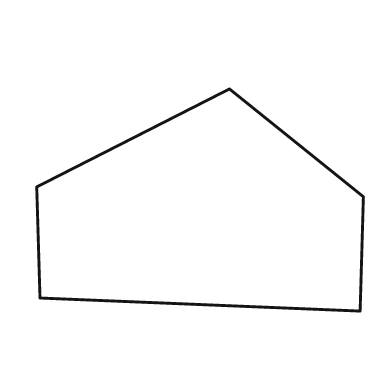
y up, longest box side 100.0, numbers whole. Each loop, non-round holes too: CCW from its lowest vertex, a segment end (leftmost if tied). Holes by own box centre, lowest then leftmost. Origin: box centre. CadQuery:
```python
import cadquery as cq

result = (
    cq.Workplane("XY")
    .moveTo(49.0, -34.0)
    .lineTo(50.0, 1.0)
    .lineTo(9.0, 34.0)
    .lineTo(-50.0, 4.0)
    .lineTo(-49.0, -30.0)
    .close()
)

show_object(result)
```